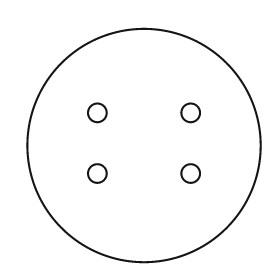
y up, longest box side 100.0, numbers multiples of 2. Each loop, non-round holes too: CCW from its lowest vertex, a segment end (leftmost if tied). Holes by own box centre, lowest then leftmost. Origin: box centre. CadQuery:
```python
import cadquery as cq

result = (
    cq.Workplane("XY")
    .moveTo(0.0, 0.0)
    .circle(50.0)
    .moveTo(-20.0, -12.0)
    .circle(4.0)
    .moveTo(20.0, -12.0)
    .circle(4.0)
    .moveTo(-20.0, 14.0)
    .circle(4.0)
    .moveTo(20.0, 14.0)
    .circle(4.0)
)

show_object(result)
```